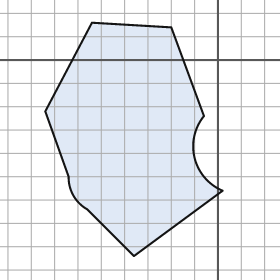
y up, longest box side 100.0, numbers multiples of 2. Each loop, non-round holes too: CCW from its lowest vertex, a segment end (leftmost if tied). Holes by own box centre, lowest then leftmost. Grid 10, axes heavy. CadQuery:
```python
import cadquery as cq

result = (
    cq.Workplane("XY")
    .moveTo(-36.0, -84.0)
    .lineTo(2.0, -56.0)
    .threePointArc((-10.0, -42.0), (-6.0, -24.0))
    .lineTo(-20.0, 14.0)
    .lineTo(-54.0, 16.0)
    .lineTo(-74.0, -22.0)
    .lineTo(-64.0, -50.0)
    .threePointArc((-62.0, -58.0), (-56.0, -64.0))
    .close()
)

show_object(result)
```